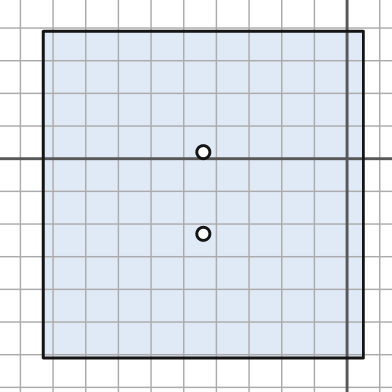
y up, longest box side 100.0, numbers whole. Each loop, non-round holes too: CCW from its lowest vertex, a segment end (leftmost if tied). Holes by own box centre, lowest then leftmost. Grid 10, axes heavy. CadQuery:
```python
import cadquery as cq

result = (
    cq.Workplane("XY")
    .moveTo(-93.0, -61.0)
    .lineTo(5.0, -61.0)
    .lineTo(5.0, 39.0)
    .lineTo(-93.0, 39.0)
    .close()
    .moveTo(-44.0, -23.0)
    .circle(2.0)
    .moveTo(-44.0, 2.0)
    .circle(2.0)
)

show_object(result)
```